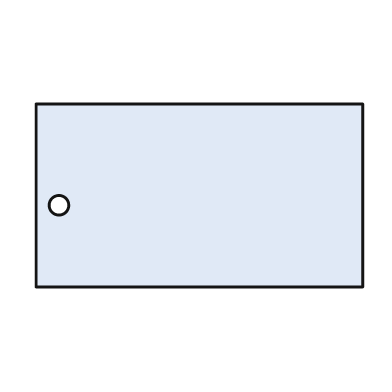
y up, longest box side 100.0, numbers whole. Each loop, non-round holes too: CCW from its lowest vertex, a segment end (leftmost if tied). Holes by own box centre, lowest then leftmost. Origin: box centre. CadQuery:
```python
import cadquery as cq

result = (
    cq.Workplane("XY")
    .moveTo(-50.0, -28.0)
    .lineTo(50.0, -28.0)
    .lineTo(50.0, 28.0)
    .lineTo(-50.0, 28.0)
    .close()
    .moveTo(-43.0, -3.0)
    .circle(3.0)
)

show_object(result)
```